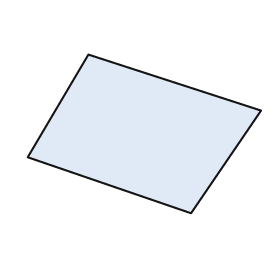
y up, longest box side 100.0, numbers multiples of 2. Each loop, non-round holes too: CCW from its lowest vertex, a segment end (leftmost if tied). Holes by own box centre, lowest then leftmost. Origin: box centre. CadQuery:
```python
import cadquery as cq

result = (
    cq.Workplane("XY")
    .moveTo(20.0, -34.0)
    .lineTo(50.0, 10.0)
    .lineTo(-24.0, 34.0)
    .lineTo(-50.0, -10.0)
    .close()
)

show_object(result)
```